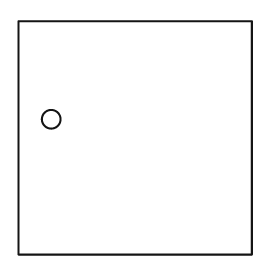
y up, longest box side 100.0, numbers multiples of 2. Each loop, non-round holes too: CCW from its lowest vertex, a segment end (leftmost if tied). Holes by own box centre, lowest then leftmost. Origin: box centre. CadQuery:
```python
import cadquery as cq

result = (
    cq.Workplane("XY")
    .moveTo(-50.0, -50.0)
    .lineTo(50.0, -50.0)
    .lineTo(50.0, 50.0)
    .lineTo(-50.0, 50.0)
    .close()
    .moveTo(-36.0, 8.0)
    .circle(4.0)
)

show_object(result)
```